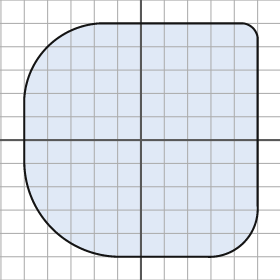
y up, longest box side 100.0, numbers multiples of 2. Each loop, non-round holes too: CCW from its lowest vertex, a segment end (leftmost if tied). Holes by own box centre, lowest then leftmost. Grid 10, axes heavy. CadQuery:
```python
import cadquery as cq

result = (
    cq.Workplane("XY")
    .moveTo(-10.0, -50.0)
    .lineTo(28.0, -50.0)
    .threePointArc((44.0, -44.0), (50.0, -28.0))
    .lineTo(50.0, 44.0)
    .threePointArc((48.0, 48.0), (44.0, 50.0))
    .lineTo(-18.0, 50.0)
    .threePointArc((-40.0, 40.0), (-50.0, 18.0))
    .lineTo(-50.0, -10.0)
    .threePointArc((-38.0, -38.0), (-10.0, -50.0))
    .close()
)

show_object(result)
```